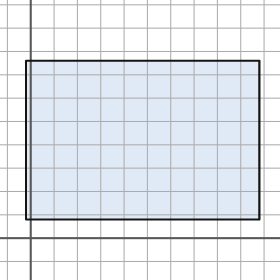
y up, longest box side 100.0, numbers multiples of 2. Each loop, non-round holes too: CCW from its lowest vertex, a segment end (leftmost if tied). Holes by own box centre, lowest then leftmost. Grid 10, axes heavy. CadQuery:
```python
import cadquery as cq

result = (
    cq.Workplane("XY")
    .moveTo(-2.0, 8.0)
    .lineTo(98.0, 8.0)
    .lineTo(98.0, 76.0)
    .lineTo(-2.0, 76.0)
    .close()
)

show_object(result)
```